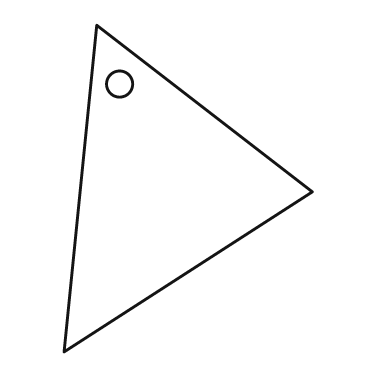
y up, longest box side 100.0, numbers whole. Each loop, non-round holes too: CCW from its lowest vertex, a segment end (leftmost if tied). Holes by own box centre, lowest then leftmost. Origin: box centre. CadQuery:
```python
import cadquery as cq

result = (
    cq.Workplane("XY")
    .moveTo(-38.0, -50.0)
    .lineTo(38.0, -1.0)
    .lineTo(-28.0, 50.0)
    .close()
    .moveTo(-21.0, 32.0)
    .circle(4.0)
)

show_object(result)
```